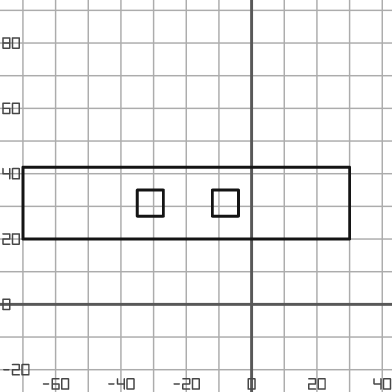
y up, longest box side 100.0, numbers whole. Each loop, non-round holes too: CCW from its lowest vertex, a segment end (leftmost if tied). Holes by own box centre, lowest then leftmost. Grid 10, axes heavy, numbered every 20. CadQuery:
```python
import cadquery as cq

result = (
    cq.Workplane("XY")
    .moveTo(-70.0, 20.0)
    .lineTo(30.0, 20.0)
    .lineTo(30.0, 42.0)
    .lineTo(-70.0, 42.0)
    .close()
    .moveTo(-35.0, 27.0)
    .lineTo(-27.0, 27.0)
    .lineTo(-27.0, 35.0)
    .lineTo(-35.0, 35.0)
    .close()
    .moveTo(-12.0, 27.0)
    .lineTo(-4.0, 27.0)
    .lineTo(-4.0, 35.0)
    .lineTo(-12.0, 35.0)
    .close()
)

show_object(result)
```